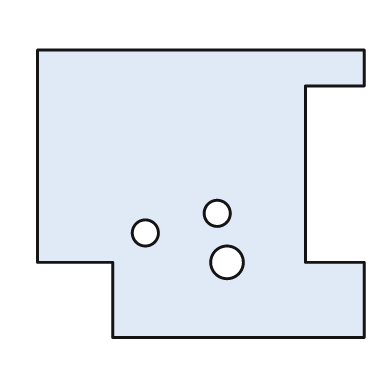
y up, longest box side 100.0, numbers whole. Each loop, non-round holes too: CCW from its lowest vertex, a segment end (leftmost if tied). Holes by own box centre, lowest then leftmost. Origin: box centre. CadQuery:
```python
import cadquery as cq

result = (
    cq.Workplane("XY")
    .moveTo(-27.0, -44.0)
    .lineTo(50.0, -44.0)
    .lineTo(50.0, -21.0)
    .lineTo(32.0, -21.0)
    .lineTo(32.0, 33.0)
    .lineTo(50.0, 33.0)
    .lineTo(50.0, 44.0)
    .lineTo(-50.0, 44.0)
    .lineTo(-50.0, -21.0)
    .lineTo(-27.0, -21.0)
    .close()
    .moveTo(8.0, -21.0)
    .circle(5.0)
    .moveTo(-17.0, -12.0)
    .circle(4.0)
    .moveTo(5.0, -6.0)
    .circle(4.0)
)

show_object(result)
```